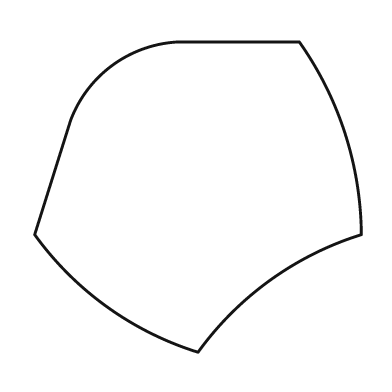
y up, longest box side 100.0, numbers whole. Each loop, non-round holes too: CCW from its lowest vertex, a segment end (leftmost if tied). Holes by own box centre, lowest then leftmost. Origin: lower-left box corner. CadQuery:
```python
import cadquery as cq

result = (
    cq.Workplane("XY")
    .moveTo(50.0, 0.0)
    .threePointArc((72.0, 22.0), (100.0, 36.0))
    .threePointArc((95.0, 67.0), (81.0, 95.0))
    .lineTo(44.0, 95.0)
    .threePointArc((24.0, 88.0), (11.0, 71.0))
    .lineTo(0.0, 36.0)
    .threePointArc((22.0, 14.0), (50.0, 0.0))
    .close()
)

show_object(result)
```